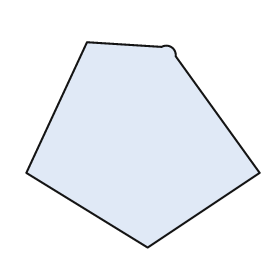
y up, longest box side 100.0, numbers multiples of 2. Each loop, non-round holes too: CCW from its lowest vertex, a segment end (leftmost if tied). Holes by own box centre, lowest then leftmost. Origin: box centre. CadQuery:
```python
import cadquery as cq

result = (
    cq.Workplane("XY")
    .moveTo(2.0, -44.0)
    .lineTo(50.0, -12.0)
    .lineTo(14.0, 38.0)
    .threePointArc((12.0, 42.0), (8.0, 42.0))
    .lineTo(-24.0, 44.0)
    .lineTo(-50.0, -12.0)
    .close()
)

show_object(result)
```